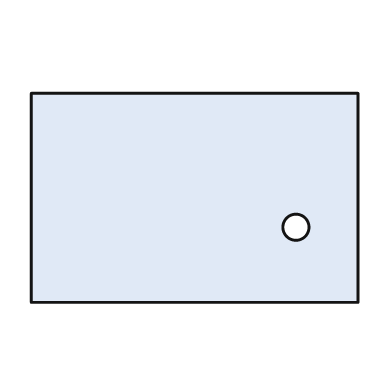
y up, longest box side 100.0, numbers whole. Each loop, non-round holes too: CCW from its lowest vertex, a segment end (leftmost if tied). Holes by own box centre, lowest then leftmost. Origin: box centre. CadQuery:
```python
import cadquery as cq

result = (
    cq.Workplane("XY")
    .moveTo(-50.0, -32.0)
    .lineTo(50.0, -32.0)
    .lineTo(50.0, 32.0)
    .lineTo(-50.0, 32.0)
    .close()
    .moveTo(31.0, -9.0)
    .circle(4.0)
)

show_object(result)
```